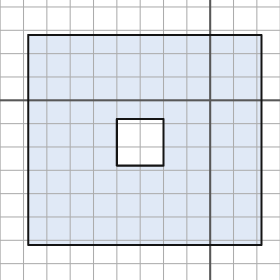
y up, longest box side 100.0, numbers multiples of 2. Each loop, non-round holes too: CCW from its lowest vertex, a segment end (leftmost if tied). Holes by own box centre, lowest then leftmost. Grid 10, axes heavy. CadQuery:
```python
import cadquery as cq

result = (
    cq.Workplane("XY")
    .moveTo(-78.0, -62.0)
    .lineTo(22.0, -62.0)
    .lineTo(22.0, 28.0)
    .lineTo(-78.0, 28.0)
    .close()
    .moveTo(-40.0, -28.0)
    .lineTo(-20.0, -28.0)
    .lineTo(-20.0, -8.0)
    .lineTo(-40.0, -8.0)
    .close()
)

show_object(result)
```